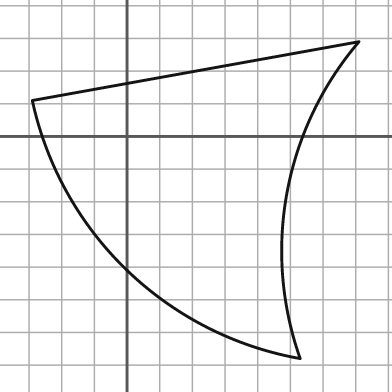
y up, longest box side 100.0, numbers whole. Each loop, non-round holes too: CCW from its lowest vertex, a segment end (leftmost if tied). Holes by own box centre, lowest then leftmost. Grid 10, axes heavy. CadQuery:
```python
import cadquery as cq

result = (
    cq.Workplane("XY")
    .moveTo(53.0, -68.0)
    .threePointArc((49.0, -17.0), (71.0, 29.0))
    .lineTo(-29.0, 11.0)
    .threePointArc((0.0, -41.0), (53.0, -68.0))
    .close()
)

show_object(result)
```